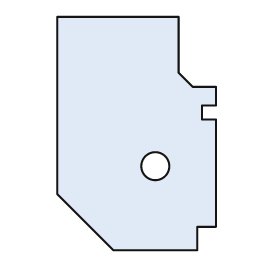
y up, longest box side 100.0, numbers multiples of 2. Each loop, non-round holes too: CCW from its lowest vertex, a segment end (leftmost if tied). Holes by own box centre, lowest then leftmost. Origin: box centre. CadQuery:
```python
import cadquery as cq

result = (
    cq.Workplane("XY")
    .moveTo(-10.0, -50.0)
    .lineTo(26.0, -50.0)
    .lineTo(26.0, -40.0)
    .lineTo(34.0, -40.0)
    .lineTo(34.0, 6.0)
    .lineTo(28.0, 6.0)
    .lineTo(28.0, 12.0)
    .lineTo(34.0, 12.0)
    .lineTo(34.0, 20.0)
    .lineTo(24.0, 20.0)
    .lineTo(18.0, 26.0)
    .lineTo(18.0, 50.0)
    .lineTo(-34.0, 50.0)
    .lineTo(-34.0, -26.0)
    .close()
    .moveTo(8.0, -14.0)
    .circle(6.0)
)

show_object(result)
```